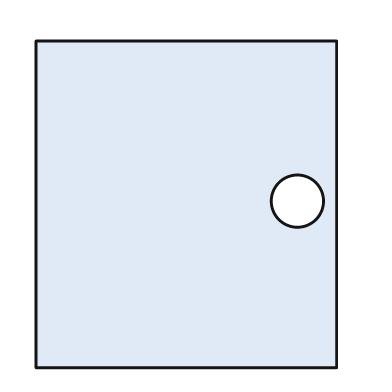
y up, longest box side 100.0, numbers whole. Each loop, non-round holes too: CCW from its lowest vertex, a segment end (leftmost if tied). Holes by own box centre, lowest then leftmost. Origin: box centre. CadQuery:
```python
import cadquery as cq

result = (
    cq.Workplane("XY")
    .moveTo(-46.0, -50.0)
    .lineTo(46.0, -50.0)
    .lineTo(46.0, 50.0)
    .lineTo(-46.0, 50.0)
    .close()
    .moveTo(34.0, 1.0)
    .circle(8.0)
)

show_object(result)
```